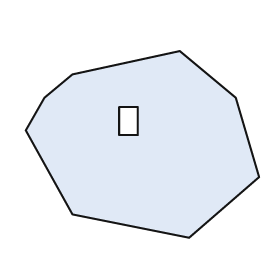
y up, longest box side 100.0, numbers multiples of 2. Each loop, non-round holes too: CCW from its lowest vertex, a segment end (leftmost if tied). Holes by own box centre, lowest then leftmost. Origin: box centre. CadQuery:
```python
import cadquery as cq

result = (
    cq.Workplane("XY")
    .moveTo(20.0, -40.0)
    .lineTo(50.0, -14.0)
    .lineTo(40.0, 20.0)
    .lineTo(16.0, 40.0)
    .lineTo(-30.0, 30.0)
    .lineTo(-42.0, 20.0)
    .lineTo(-50.0, 6.0)
    .lineTo(-30.0, -30.0)
    .close()
    .moveTo(-10.0, 4.0)
    .lineTo(-2.0, 4.0)
    .lineTo(-2.0, 16.0)
    .lineTo(-10.0, 16.0)
    .close()
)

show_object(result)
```